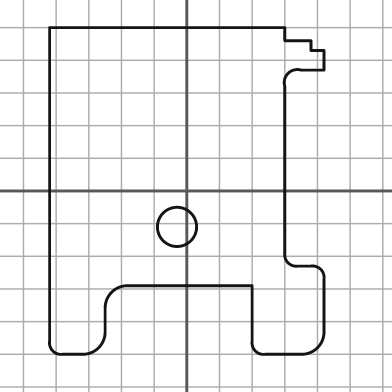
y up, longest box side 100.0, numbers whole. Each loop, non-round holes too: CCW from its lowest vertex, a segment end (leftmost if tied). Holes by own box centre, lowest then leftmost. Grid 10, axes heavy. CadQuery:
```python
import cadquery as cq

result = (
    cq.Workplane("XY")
    .moveTo(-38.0, -50.0)
    .lineTo(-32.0, -50.0)
    .threePointArc((-27.0, -48.0), (-25.0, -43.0))
    .lineTo(-25.0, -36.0)
    .threePointArc((-23.0, -31.0), (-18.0, -29.0))
    .lineTo(20.0, -29.0)
    .lineTo(20.0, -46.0)
    .threePointArc((21.0, -49.0), (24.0, -50.0))
    .lineTo(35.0, -50.0)
    .threePointArc((40.0, -48.0), (42.0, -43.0))
    .lineTo(42.0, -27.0)
    .threePointArc((41.0, -24.0), (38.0, -23.0))
    .lineTo(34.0, -23.0)
    .threePointArc((31.0, -22.0), (30.0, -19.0))
    .lineTo(30.0, 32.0)
    .threePointArc((31.0, 36.0), (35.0, 37.0))
    .lineTo(42.0, 37.0)
    .lineTo(42.0, 43.0)
    .lineTo(38.0, 43.0)
    .lineTo(38.0, 46.0)
    .lineTo(30.0, 46.0)
    .lineTo(30.0, 50.0)
    .lineTo(-42.0, 50.0)
    .lineTo(-42.0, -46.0)
    .threePointArc((-41.0, -49.0), (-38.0, -50.0))
    .close()
    .moveTo(-3.0, -11.0)
    .circle(6.0)
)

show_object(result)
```